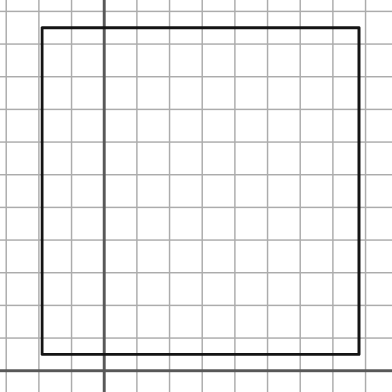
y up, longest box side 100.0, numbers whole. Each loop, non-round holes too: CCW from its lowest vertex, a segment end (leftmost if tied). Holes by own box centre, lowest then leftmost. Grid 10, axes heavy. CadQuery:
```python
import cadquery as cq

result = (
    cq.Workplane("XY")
    .moveTo(-19.0, 5.0)
    .lineTo(78.0, 5.0)
    .lineTo(78.0, 105.0)
    .lineTo(-19.0, 105.0)
    .close()
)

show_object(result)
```